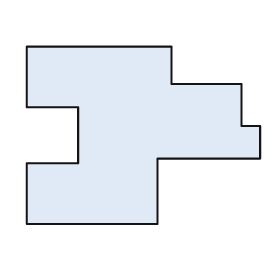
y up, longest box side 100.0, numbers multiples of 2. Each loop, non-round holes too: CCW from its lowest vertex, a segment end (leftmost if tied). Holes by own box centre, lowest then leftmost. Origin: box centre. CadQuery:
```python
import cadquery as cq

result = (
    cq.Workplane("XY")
    .moveTo(-50.0, -38.0)
    .lineTo(6.0, -38.0)
    .lineTo(6.0, -10.0)
    .lineTo(50.0, -10.0)
    .lineTo(50.0, 4.0)
    .lineTo(42.0, 4.0)
    .lineTo(42.0, 22.0)
    .lineTo(12.0, 22.0)
    .lineTo(12.0, 38.0)
    .lineTo(-50.0, 38.0)
    .lineTo(-50.0, 12.0)
    .lineTo(-28.0, 12.0)
    .lineTo(-28.0, -12.0)
    .lineTo(-50.0, -12.0)
    .close()
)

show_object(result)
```